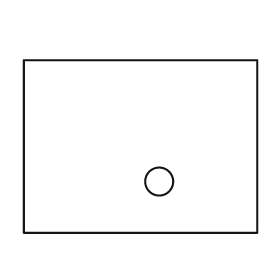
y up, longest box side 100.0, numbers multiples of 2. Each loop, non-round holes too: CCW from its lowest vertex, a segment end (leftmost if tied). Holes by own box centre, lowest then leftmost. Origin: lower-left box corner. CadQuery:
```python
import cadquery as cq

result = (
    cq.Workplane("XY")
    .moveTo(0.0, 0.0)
    .lineTo(100.0, 0.0)
    .lineTo(100.0, 74.0)
    .lineTo(0.0, 74.0)
    .close()
    .moveTo(58.0, 22.0)
    .circle(6.0)
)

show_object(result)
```